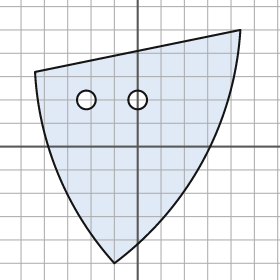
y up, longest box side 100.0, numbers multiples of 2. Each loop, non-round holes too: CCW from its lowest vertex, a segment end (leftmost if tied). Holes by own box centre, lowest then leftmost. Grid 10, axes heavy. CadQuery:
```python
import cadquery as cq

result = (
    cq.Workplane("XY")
    .moveTo(-10.0, -50.0)
    .threePointArc((28.0, -6.0), (44.0, 50.0))
    .lineTo(-44.0, 32.0)
    .threePointArc((-34.0, -12.0), (-10.0, -50.0))
    .close()
    .moveTo(-22.0, 20.0)
    .circle(4.0)
    .moveTo(0.0, 20.0)
    .circle(4.0)
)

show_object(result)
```